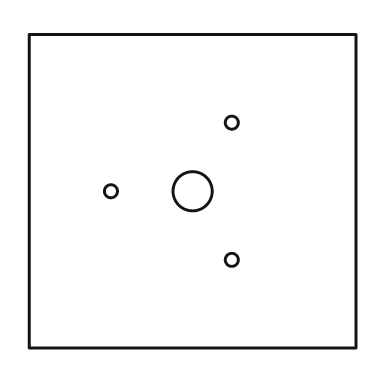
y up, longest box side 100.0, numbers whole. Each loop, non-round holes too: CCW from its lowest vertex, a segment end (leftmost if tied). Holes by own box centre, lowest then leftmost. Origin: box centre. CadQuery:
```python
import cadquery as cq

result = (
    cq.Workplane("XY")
    .moveTo(-50.0, -48.0)
    .lineTo(50.0, -48.0)
    .lineTo(50.0, 48.0)
    .lineTo(-50.0, 48.0)
    .close()
    .moveTo(12.0, -21.0)
    .circle(2.0)
    .moveTo(-25.0, 0.0)
    .circle(2.0)
    .moveTo(0.0, 0.0)
    .circle(6.0)
    .moveTo(12.0, 21.0)
    .circle(2.0)
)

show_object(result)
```